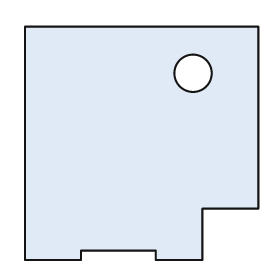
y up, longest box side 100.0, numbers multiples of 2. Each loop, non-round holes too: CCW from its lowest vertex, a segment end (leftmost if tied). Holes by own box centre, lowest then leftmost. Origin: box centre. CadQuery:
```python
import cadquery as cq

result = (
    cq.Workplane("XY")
    .moveTo(-50.0, -50.0)
    .lineTo(-26.0, -50.0)
    .lineTo(-26.0, -46.0)
    .lineTo(6.0, -46.0)
    .lineTo(6.0, -50.0)
    .lineTo(26.0, -50.0)
    .lineTo(26.0, -28.0)
    .lineTo(50.0, -28.0)
    .lineTo(50.0, 50.0)
    .lineTo(-50.0, 50.0)
    .close()
    .moveTo(22.0, 30.0)
    .circle(8.0)
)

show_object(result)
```